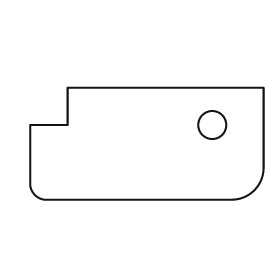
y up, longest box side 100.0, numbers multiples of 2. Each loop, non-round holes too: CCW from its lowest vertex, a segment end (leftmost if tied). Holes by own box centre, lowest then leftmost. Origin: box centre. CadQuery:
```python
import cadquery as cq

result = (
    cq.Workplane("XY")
    .moveTo(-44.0, -24.0)
    .lineTo(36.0, -24.0)
    .threePointArc((46.0, -20.0), (50.0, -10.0))
    .lineTo(50.0, 24.0)
    .lineTo(-34.0, 24.0)
    .lineTo(-34.0, 8.0)
    .lineTo(-50.0, 8.0)
    .lineTo(-50.0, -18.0)
    .threePointArc((-48.0, -22.0), (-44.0, -24.0))
    .close()
    .moveTo(28.0, 8.0)
    .circle(6.0)
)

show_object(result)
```